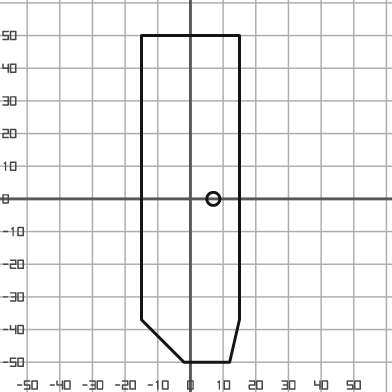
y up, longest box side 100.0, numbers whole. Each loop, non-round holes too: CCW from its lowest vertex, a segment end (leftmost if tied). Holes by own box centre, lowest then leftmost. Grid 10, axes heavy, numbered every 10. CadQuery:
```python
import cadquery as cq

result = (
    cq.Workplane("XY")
    .moveTo(-2.0, -50.0)
    .lineTo(12.0, -50.0)
    .lineTo(15.0, -37.0)
    .lineTo(15.0, 50.0)
    .lineTo(-15.0, 50.0)
    .lineTo(-15.0, -37.0)
    .close()
    .moveTo(7.0, 0.0)
    .circle(2.0)
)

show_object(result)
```